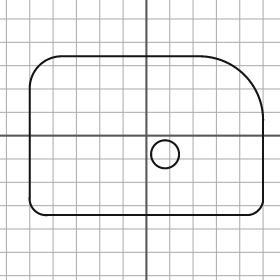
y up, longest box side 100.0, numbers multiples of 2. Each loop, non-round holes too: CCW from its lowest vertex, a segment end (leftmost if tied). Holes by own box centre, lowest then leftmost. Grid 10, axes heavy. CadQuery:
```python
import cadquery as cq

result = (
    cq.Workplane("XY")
    .moveTo(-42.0, -34.0)
    .lineTo(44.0, -34.0)
    .threePointArc((48.0, -32.0), (50.0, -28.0))
    .lineTo(50.0, 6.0)
    .threePointArc((42.0, 26.0), (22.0, 34.0))
    .lineTo(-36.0, 34.0)
    .threePointArc((-46.0, 30.0), (-50.0, 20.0))
    .lineTo(-50.0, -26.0)
    .threePointArc((-48.0, -32.0), (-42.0, -34.0))
    .close()
    .moveTo(8.0, -8.0)
    .circle(6.0)
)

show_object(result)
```